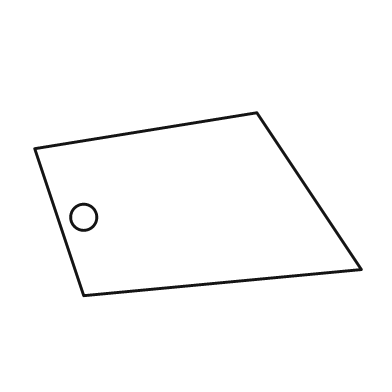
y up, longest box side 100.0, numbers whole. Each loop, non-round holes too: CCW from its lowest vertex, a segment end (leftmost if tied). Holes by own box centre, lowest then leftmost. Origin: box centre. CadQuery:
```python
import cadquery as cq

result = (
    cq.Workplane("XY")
    .moveTo(-35.0, -28.0)
    .lineTo(50.0, -20.0)
    .lineTo(18.0, 28.0)
    .lineTo(-50.0, 17.0)
    .close()
    .moveTo(-35.0, -4.0)
    .circle(4.0)
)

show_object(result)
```